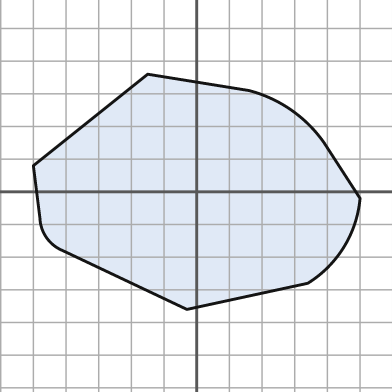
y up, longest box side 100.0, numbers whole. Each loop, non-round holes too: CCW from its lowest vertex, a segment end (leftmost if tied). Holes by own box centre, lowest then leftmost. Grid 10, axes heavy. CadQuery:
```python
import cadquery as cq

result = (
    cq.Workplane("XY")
    .moveTo(-3.0, -36.0)
    .lineTo(34.0, -28.0)
    .threePointArc((45.0, -17.0), (50.0, -2.0))
    .lineTo(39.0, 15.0)
    .threePointArc((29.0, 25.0), (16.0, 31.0))
    .lineTo(-15.0, 36.0)
    .lineTo(-50.0, 8.0)
    .lineTo(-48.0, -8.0)
    .threePointArc((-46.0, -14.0), (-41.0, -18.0))
    .close()
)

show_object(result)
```